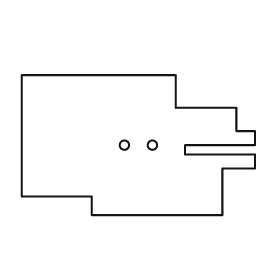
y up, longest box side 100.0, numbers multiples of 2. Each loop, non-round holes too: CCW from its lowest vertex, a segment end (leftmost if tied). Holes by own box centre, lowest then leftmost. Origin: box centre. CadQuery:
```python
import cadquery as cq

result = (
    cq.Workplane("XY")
    .moveTo(-20.0, -30.0)
    .lineTo(36.0, -30.0)
    .lineTo(36.0, -10.0)
    .lineTo(50.0, -10.0)
    .lineTo(50.0, -4.0)
    .lineTo(20.0, -4.0)
    .lineTo(20.0, 0.0)
    .lineTo(50.0, 0.0)
    .lineTo(50.0, 6.0)
    .lineTo(42.0, 6.0)
    .lineTo(42.0, 16.0)
    .lineTo(16.0, 16.0)
    .lineTo(16.0, 30.0)
    .lineTo(-50.0, 30.0)
    .lineTo(-50.0, -22.0)
    .lineTo(-20.0, -22.0)
    .close()
    .moveTo(-6.0, 0.0)
    .circle(2.0)
    .moveTo(6.0, 0.0)
    .circle(2.0)
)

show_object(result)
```